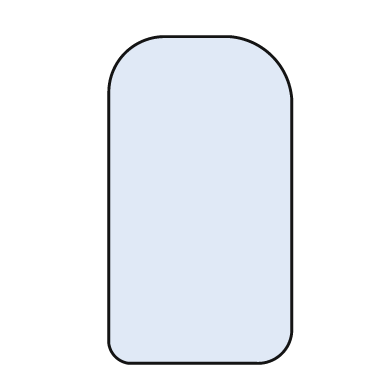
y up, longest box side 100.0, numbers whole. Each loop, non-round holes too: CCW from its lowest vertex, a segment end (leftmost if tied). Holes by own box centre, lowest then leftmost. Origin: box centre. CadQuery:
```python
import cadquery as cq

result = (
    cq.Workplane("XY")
    .moveTo(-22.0, -50.0)
    .lineTo(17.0, -50.0)
    .threePointArc((25.0, -47.0), (28.0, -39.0))
    .lineTo(28.0, 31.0)
    .threePointArc((22.0, 44.0), (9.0, 50.0))
    .lineTo(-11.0, 50.0)
    .threePointArc((-23.0, 45.0), (-28.0, 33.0))
    .lineTo(-28.0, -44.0)
    .threePointArc((-26.0, -48.0), (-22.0, -50.0))
    .close()
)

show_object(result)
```